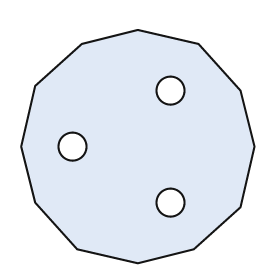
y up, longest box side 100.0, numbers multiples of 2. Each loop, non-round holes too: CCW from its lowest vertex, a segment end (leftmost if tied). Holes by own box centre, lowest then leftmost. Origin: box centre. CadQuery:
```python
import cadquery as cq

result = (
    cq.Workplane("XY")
    .moveTo(0.0, -50.0)
    .lineTo(24.0, -44.0)
    .lineTo(44.0, -26.0)
    .lineTo(50.0, 0.0)
    .lineTo(44.0, 24.0)
    .lineTo(26.0, 44.0)
    .lineTo(0.0, 50.0)
    .lineTo(-24.0, 44.0)
    .lineTo(-44.0, 26.0)
    .lineTo(-50.0, 0.0)
    .lineTo(-44.0, -24.0)
    .lineTo(-26.0, -44.0)
    .close()
    .moveTo(14.0, -24.0)
    .circle(6.0)
    .moveTo(-28.0, 0.0)
    .circle(6.0)
    .moveTo(14.0, 24.0)
    .circle(6.0)
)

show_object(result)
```